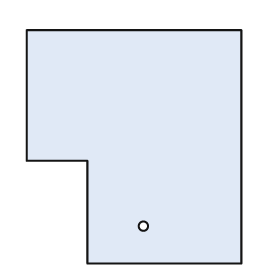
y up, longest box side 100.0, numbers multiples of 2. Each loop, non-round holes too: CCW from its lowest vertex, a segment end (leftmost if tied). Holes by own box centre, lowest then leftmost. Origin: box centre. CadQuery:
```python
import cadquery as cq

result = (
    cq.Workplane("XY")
    .moveTo(-20.0, -50.0)
    .lineTo(46.0, -50.0)
    .lineTo(46.0, 50.0)
    .lineTo(-46.0, 50.0)
    .lineTo(-46.0, -6.0)
    .lineTo(-20.0, -6.0)
    .close()
    .moveTo(4.0, -34.0)
    .circle(2.0)
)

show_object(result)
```